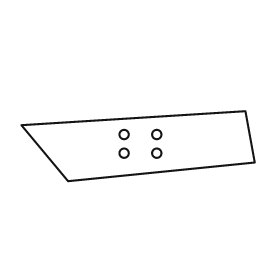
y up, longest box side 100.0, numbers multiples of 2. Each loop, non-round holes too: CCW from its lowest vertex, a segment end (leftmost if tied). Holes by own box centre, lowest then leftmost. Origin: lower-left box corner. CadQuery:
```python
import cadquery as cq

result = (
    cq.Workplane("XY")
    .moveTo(20.0, 0.0)
    .lineTo(100.0, 8.0)
    .lineTo(96.0, 30.0)
    .lineTo(0.0, 24.0)
    .close()
    .moveTo(44.0, 12.0)
    .circle(2.0)
    .moveTo(58.0, 12.0)
    .circle(2.0)
    .moveTo(44.0, 20.0)
    .circle(2.0)
    .moveTo(58.0, 20.0)
    .circle(2.0)
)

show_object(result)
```